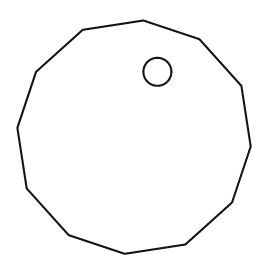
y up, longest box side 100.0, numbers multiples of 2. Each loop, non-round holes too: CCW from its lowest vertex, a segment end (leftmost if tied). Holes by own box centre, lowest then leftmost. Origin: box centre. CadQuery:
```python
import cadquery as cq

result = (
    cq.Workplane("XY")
    .moveTo(-4.0, -50.0)
    .lineTo(22.0, -46.0)
    .lineTo(42.0, -28.0)
    .lineTo(50.0, -4.0)
    .lineTo(46.0, 22.0)
    .lineTo(28.0, 42.0)
    .lineTo(4.0, 50.0)
    .lineTo(-22.0, 46.0)
    .lineTo(-42.0, 28.0)
    .lineTo(-50.0, 4.0)
    .lineTo(-46.0, -22.0)
    .lineTo(-28.0, -42.0)
    .close()
    .moveTo(10.0, 28.0)
    .circle(6.0)
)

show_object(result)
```